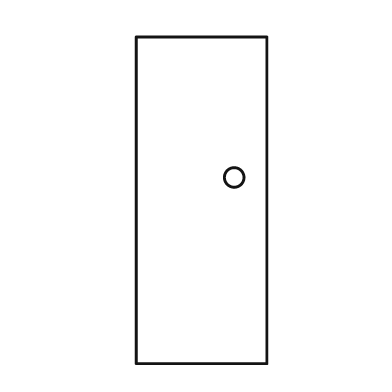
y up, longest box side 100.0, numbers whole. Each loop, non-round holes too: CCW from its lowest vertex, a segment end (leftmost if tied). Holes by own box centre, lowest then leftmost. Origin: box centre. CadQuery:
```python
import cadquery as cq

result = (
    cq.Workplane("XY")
    .moveTo(-20.0, -50.0)
    .lineTo(20.0, -50.0)
    .lineTo(20.0, 50.0)
    .lineTo(-20.0, 50.0)
    .close()
    .moveTo(10.0, 7.0)
    .circle(3.0)
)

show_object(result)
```